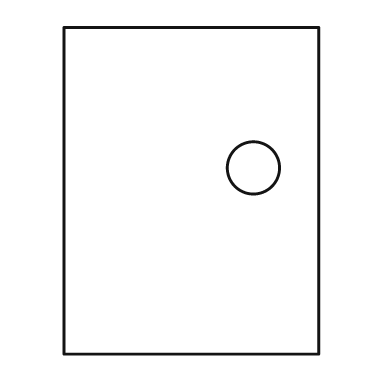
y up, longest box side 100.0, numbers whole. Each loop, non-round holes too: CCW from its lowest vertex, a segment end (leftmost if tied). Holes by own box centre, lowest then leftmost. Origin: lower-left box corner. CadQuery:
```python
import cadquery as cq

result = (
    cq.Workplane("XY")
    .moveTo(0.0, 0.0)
    .lineTo(78.0, 0.0)
    .lineTo(78.0, 100.0)
    .lineTo(0.0, 100.0)
    .close()
    .moveTo(58.0, 57.0)
    .circle(8.0)
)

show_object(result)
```